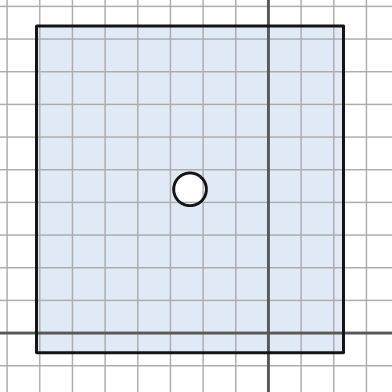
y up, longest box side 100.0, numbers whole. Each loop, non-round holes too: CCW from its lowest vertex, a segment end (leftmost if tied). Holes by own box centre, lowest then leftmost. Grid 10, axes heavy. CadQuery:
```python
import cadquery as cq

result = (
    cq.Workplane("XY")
    .moveTo(-71.0, -6.0)
    .lineTo(23.0, -6.0)
    .lineTo(23.0, 94.0)
    .lineTo(-71.0, 94.0)
    .close()
    .moveTo(-24.0, 44.0)
    .circle(5.0)
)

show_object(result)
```